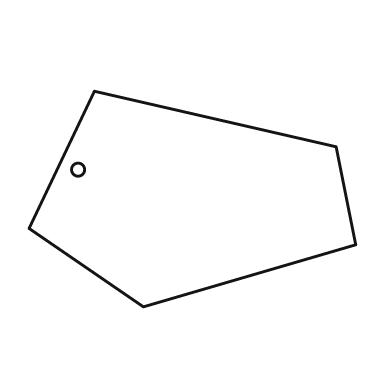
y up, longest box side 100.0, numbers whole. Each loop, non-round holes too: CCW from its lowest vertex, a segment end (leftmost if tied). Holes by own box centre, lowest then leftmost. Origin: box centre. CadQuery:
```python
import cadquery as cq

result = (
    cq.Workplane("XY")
    .moveTo(-15.0, -33.0)
    .lineTo(50.0, -14.0)
    .lineTo(44.0, 16.0)
    .lineTo(-30.0, 33.0)
    .lineTo(-50.0, -9.0)
    .close()
    .moveTo(-35.0, 9.0)
    .circle(2.0)
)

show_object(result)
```